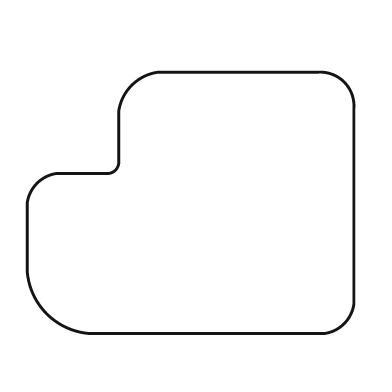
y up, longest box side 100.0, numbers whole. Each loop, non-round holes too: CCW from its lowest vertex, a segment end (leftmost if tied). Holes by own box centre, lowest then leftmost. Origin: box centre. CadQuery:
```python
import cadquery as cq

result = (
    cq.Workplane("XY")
    .moveTo(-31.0, -40.0)
    .lineTo(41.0, -40.0)
    .threePointArc((47.0, -37.0), (50.0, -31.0))
    .lineTo(50.0, 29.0)
    .threePointArc((47.0, 37.0), (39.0, 40.0))
    .lineTo(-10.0, 40.0)
    .threePointArc((-18.0, 36.0), (-22.0, 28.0))
    .lineTo(-22.0, 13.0)
    .threePointArc((-23.0, 10.0), (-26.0, 9.0))
    .lineTo(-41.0, 9.0)
    .threePointArc((-47.0, 6.0), (-50.0, 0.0))
    .lineTo(-50.0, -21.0)
    .threePointArc((-44.0, -34.0), (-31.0, -40.0))
    .close()
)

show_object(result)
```